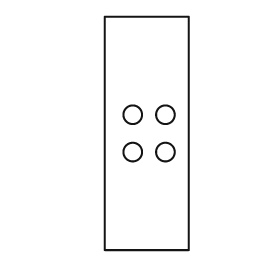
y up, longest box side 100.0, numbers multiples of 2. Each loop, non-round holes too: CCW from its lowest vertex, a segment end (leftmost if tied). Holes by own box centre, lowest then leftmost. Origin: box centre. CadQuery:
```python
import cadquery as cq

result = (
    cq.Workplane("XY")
    .moveTo(-18.0, -50.0)
    .lineTo(18.0, -50.0)
    .lineTo(18.0, 50.0)
    .lineTo(-18.0, 50.0)
    .close()
    .moveTo(-6.0, -8.0)
    .circle(4.0)
    .moveTo(8.0, -8.0)
    .circle(4.0)
    .moveTo(-6.0, 8.0)
    .circle(4.0)
    .moveTo(8.0, 8.0)
    .circle(4.0)
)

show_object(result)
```